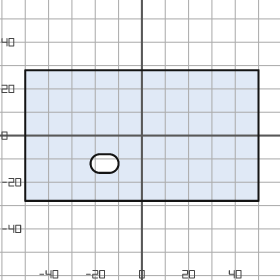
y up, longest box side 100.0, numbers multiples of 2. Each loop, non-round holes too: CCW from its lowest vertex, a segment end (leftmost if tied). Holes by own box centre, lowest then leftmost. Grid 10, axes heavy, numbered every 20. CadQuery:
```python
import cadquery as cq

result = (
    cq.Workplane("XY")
    .moveTo(-50.0, -28.0)
    .lineTo(50.0, -28.0)
    .lineTo(50.0, 28.0)
    .lineTo(-50.0, 28.0)
    .close()
    .moveTo(-18.0, -16.0)
    .lineTo(-14.0, -16.0)
    .threePointArc((-10.0, -12.0), (-14.0, -8.0))
    .lineTo(-18.0, -8.0)
    .threePointArc((-22.0, -12.0), (-18.0, -16.0))
    .close()
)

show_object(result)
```